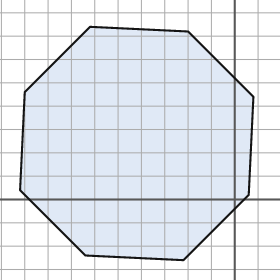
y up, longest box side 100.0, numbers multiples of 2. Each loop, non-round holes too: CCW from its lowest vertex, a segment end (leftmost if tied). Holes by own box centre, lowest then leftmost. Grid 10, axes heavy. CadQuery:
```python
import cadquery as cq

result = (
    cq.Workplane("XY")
    .moveTo(-22.0, -26.0)
    .lineTo(6.0, 2.0)
    .lineTo(8.0, 44.0)
    .lineTo(-20.0, 72.0)
    .lineTo(-62.0, 74.0)
    .lineTo(-90.0, 46.0)
    .lineTo(-92.0, 4.0)
    .lineTo(-64.0, -24.0)
    .close()
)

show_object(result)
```